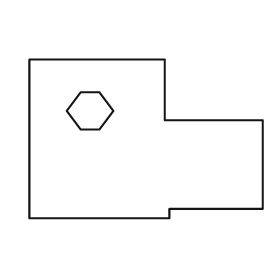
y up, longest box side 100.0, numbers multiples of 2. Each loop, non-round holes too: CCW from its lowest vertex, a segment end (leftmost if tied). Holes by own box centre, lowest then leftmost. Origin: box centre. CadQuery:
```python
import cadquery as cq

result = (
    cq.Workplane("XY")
    .moveTo(-50.0, -34.0)
    .lineTo(10.0, -34.0)
    .lineTo(10.0, -30.0)
    .lineTo(50.0, -30.0)
    .lineTo(50.0, 8.0)
    .lineTo(8.0, 8.0)
    .lineTo(8.0, 34.0)
    .lineTo(-50.0, 34.0)
    .close()
    .moveTo(-28.0, 4.0)
    .lineTo(-20.0, 4.0)
    .lineTo(-14.0, 12.0)
    .lineTo(-20.0, 20.0)
    .lineTo(-28.0, 20.0)
    .lineTo(-34.0, 12.0)
    .close()
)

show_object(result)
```